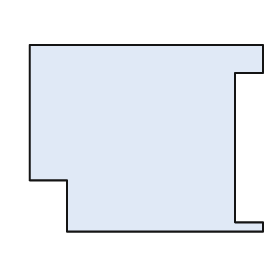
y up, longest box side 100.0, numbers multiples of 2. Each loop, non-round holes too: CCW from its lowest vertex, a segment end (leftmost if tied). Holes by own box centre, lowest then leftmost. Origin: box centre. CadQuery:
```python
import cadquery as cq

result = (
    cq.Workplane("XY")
    .moveTo(-34.0, -40.0)
    .lineTo(50.0, -40.0)
    .lineTo(50.0, -36.0)
    .lineTo(38.0, -36.0)
    .lineTo(38.0, 28.0)
    .lineTo(50.0, 28.0)
    .lineTo(50.0, 40.0)
    .lineTo(-50.0, 40.0)
    .lineTo(-50.0, -18.0)
    .lineTo(-34.0, -18.0)
    .close()
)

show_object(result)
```